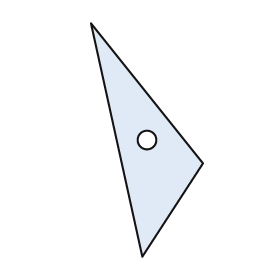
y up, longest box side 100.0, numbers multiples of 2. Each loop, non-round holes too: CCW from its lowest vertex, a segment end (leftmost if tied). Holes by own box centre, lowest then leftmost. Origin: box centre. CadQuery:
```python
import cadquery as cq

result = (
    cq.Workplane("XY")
    .moveTo(-2.0, -50.0)
    .lineTo(24.0, -10.0)
    .lineTo(-24.0, 50.0)
    .close()
    .moveTo(0.0, 0.0)
    .circle(4.0)
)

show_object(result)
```